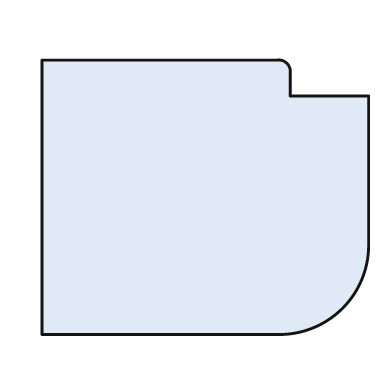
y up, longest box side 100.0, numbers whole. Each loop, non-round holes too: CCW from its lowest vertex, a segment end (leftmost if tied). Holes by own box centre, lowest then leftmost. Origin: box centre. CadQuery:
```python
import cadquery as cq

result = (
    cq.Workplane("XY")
    .moveTo(-50.0, -42.0)
    .lineTo(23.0, -42.0)
    .threePointArc((42.0, -34.0), (50.0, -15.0))
    .lineTo(50.0, 31.0)
    .lineTo(26.0, 31.0)
    .lineTo(26.0, 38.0)
    .threePointArc((25.0, 41.0), (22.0, 42.0))
    .lineTo(-50.0, 42.0)
    .close()
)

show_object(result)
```